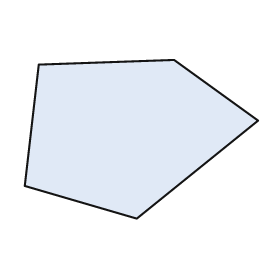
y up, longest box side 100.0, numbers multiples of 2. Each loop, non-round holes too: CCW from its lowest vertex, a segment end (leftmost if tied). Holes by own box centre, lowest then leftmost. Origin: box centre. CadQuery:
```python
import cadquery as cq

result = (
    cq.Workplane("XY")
    .moveTo(-2.0, -34.0)
    .lineTo(50.0, 8.0)
    .lineTo(14.0, 34.0)
    .lineTo(-44.0, 32.0)
    .lineTo(-50.0, -20.0)
    .close()
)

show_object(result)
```